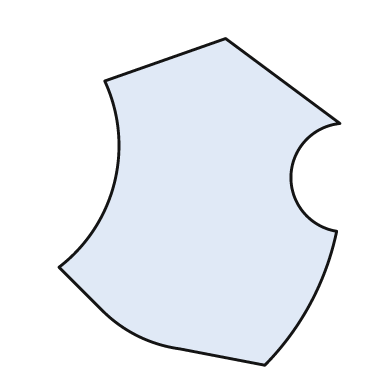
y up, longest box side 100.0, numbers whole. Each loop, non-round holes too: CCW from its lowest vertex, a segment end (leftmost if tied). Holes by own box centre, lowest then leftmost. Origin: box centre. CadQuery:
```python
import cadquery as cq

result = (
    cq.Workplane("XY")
    .moveTo(20.0, -50.0)
    .threePointArc((34.0, -31.0), (42.0, -9.0))
    .threePointArc((28.0, 8.0), (43.0, 24.0))
    .lineTo(8.0, 50.0)
    .lineTo(-29.0, 37.0)
    .threePointArc((-26.0, 6.0), (-43.0, -20.0))
    .lineTo(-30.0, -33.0)
    .threePointArc((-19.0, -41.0), (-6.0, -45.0))
    .close()
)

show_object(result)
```